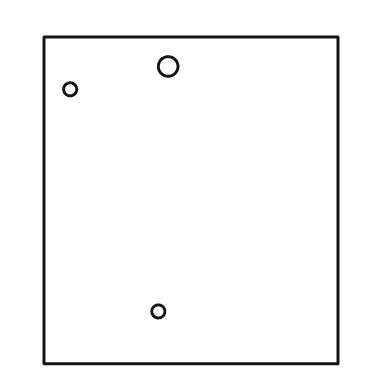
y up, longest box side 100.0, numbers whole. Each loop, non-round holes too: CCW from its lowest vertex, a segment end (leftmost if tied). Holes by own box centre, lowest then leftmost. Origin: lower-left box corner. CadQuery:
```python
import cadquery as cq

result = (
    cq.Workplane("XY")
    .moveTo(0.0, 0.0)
    .lineTo(90.0, 0.0)
    .lineTo(90.0, 100.0)
    .lineTo(0.0, 100.0)
    .close()
    .moveTo(35.0, 16.0)
    .circle(2.0)
    .moveTo(8.0, 84.0)
    .circle(2.0)
    .moveTo(38.0, 91.0)
    .circle(3.0)
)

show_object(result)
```